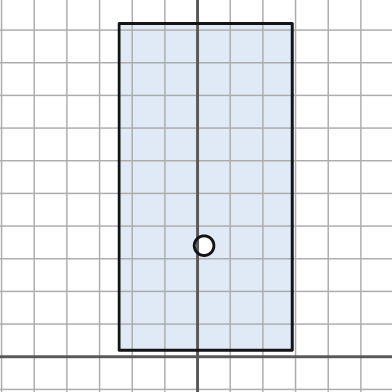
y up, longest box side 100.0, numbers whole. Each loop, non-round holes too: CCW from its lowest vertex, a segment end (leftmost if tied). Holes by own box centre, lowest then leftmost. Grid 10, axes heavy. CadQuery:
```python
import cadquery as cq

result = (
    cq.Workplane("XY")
    .moveTo(-24.0, 2.0)
    .lineTo(29.0, 2.0)
    .lineTo(29.0, 102.0)
    .lineTo(-24.0, 102.0)
    .close()
    .moveTo(2.0, 34.0)
    .circle(3.0)
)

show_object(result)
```